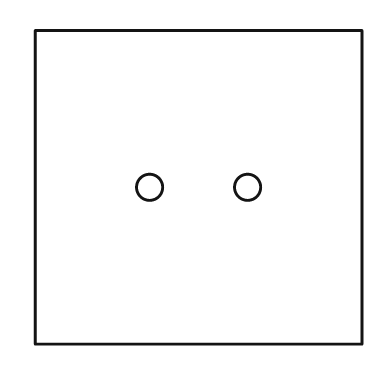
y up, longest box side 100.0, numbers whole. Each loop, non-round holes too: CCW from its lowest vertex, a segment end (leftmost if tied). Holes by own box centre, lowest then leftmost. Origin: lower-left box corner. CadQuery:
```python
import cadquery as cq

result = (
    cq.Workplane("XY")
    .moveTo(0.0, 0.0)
    .lineTo(100.0, 0.0)
    .lineTo(100.0, 96.0)
    .lineTo(0.0, 96.0)
    .close()
    .moveTo(35.0, 48.0)
    .circle(4.0)
    .moveTo(65.0, 48.0)
    .circle(4.0)
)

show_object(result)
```